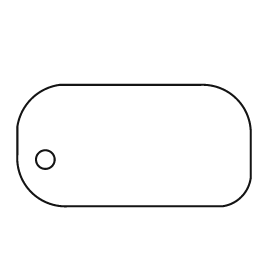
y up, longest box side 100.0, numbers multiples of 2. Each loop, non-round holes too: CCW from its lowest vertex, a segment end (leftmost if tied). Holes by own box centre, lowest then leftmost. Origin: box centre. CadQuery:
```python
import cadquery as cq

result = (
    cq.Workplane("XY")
    .moveTo(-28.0, -26.0)
    .lineTo(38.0, -26.0)
    .threePointArc((46.0, -22.0), (50.0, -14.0))
    .lineTo(50.0, 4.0)
    .threePointArc((44.0, 20.0), (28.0, 26.0))
    .lineTo(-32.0, 26.0)
    .threePointArc((-44.0, 20.0), (-50.0, 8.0))
    .lineTo(-50.0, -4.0)
    .threePointArc((-44.0, -20.0), (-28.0, -26.0))
    .close()
    .moveTo(-38.0, -6.0)
    .circle(4.0)
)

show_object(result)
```